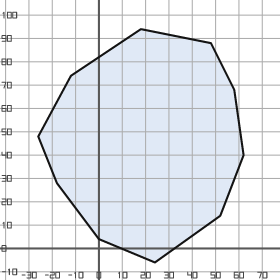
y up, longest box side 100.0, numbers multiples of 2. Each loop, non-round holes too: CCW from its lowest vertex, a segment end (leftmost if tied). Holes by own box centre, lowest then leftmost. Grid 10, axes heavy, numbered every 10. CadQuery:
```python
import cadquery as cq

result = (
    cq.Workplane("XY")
    .moveTo(24.0, -6.0)
    .lineTo(52.0, 14.0)
    .lineTo(62.0, 40.0)
    .lineTo(58.0, 68.0)
    .lineTo(48.0, 88.0)
    .lineTo(18.0, 94.0)
    .lineTo(-12.0, 74.0)
    .lineTo(-26.0, 48.0)
    .lineTo(-18.0, 28.0)
    .lineTo(0.0, 4.0)
    .close()
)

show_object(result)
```